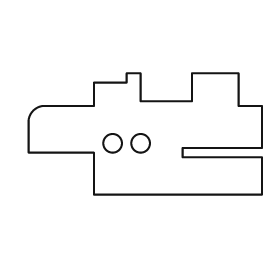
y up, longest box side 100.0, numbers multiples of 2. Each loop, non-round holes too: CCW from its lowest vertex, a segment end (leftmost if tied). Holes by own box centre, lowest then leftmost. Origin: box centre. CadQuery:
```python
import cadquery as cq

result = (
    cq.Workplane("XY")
    .moveTo(-22.0, -26.0)
    .lineTo(50.0, -26.0)
    .lineTo(50.0, -10.0)
    .lineTo(16.0, -10.0)
    .lineTo(16.0, -6.0)
    .lineTo(50.0, -6.0)
    .lineTo(50.0, 12.0)
    .lineTo(40.0, 12.0)
    .lineTo(40.0, 26.0)
    .lineTo(20.0, 26.0)
    .lineTo(20.0, 14.0)
    .lineTo(-2.0, 14.0)
    .lineTo(-2.0, 26.0)
    .lineTo(-8.0, 26.0)
    .lineTo(-8.0, 22.0)
    .lineTo(-22.0, 22.0)
    .lineTo(-22.0, 12.0)
    .lineTo(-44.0, 12.0)
    .threePointArc((-48.0, 10.0), (-50.0, 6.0))
    .lineTo(-50.0, -8.0)
    .lineTo(-22.0, -8.0)
    .close()
    .moveTo(-14.0, -4.0)
    .circle(4.0)
    .moveTo(-2.0, -4.0)
    .circle(4.0)
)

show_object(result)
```